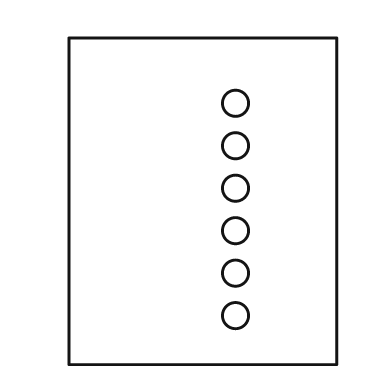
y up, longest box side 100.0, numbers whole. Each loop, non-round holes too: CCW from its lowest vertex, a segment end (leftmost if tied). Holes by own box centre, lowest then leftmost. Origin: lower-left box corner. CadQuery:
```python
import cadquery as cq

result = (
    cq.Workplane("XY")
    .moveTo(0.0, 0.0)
    .lineTo(82.0, 0.0)
    .lineTo(82.0, 100.0)
    .lineTo(0.0, 100.0)
    .close()
    .moveTo(51.0, 15.0)
    .circle(4.0)
    .moveTo(51.0, 28.0)
    .circle(4.0)
    .moveTo(51.0, 41.0)
    .circle(4.0)
    .moveTo(51.0, 54.0)
    .circle(4.0)
    .moveTo(51.0, 67.0)
    .circle(4.0)
    .moveTo(51.0, 80.0)
    .circle(4.0)
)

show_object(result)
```